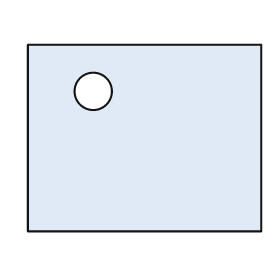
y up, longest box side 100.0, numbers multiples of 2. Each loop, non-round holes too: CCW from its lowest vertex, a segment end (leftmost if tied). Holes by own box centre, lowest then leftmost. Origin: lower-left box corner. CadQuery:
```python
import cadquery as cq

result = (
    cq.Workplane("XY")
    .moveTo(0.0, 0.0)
    .lineTo(100.0, 0.0)
    .lineTo(100.0, 80.0)
    .lineTo(0.0, 80.0)
    .close()
    .moveTo(28.0, 60.0)
    .circle(8.0)
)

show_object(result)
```